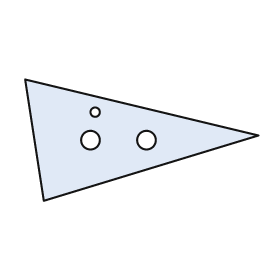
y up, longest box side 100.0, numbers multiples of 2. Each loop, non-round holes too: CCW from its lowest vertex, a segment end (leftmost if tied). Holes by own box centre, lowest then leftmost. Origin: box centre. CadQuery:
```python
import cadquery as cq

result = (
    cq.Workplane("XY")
    .moveTo(-42.0, -26.0)
    .lineTo(50.0, 2.0)
    .lineTo(-50.0, 26.0)
    .close()
    .moveTo(-22.0, 0.0)
    .circle(4.0)
    .moveTo(2.0, 0.0)
    .circle(4.0)
    .moveTo(-20.0, 12.0)
    .circle(2.0)
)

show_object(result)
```